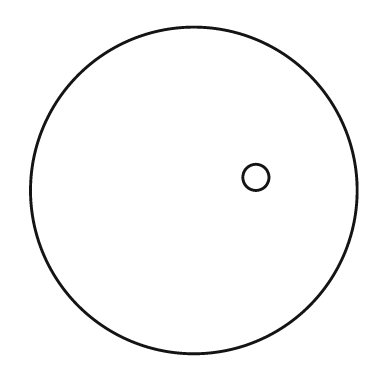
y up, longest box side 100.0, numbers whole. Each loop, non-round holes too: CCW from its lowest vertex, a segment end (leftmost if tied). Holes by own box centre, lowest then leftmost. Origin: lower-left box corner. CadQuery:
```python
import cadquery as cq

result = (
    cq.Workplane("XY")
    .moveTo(50.0, 50.0)
    .circle(50.0)
    .moveTo(69.0, 54.0)
    .circle(4.0)
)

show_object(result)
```